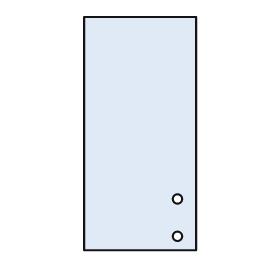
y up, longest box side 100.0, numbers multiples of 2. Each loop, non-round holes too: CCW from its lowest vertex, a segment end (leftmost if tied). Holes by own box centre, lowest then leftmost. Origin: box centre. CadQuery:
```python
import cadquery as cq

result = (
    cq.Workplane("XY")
    .moveTo(-24.0, -50.0)
    .lineTo(24.0, -50.0)
    .lineTo(24.0, 50.0)
    .lineTo(-24.0, 50.0)
    .close()
    .moveTo(16.0, -44.0)
    .circle(2.0)
    .moveTo(16.0, -28.0)
    .circle(2.0)
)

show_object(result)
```